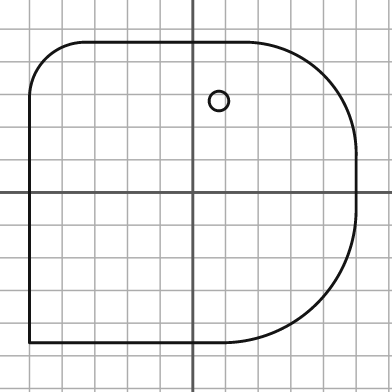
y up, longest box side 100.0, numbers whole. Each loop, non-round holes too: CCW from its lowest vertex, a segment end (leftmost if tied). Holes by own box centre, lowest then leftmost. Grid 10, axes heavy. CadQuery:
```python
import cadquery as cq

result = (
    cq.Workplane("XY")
    .moveTo(-50.0, -46.0)
    .lineTo(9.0, -46.0)
    .threePointArc((38.0, -34.0), (50.0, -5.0))
    .lineTo(50.0, 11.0)
    .threePointArc((40.0, 36.0), (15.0, 46.0))
    .lineTo(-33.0, 46.0)
    .threePointArc((-45.0, 41.0), (-50.0, 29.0))
    .close()
    .moveTo(8.0, 28.0)
    .circle(3.0)
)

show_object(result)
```